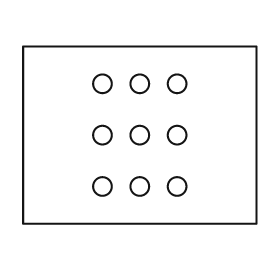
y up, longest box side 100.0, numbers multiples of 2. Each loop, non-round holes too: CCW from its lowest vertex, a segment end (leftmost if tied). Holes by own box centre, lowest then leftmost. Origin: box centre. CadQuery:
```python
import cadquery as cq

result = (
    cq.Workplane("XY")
    .moveTo(-50.0, -38.0)
    .lineTo(50.0, -38.0)
    .lineTo(50.0, 38.0)
    .lineTo(-50.0, 38.0)
    .close()
    .moveTo(-16.0, -22.0)
    .circle(4.0)
    .moveTo(0.0, -22.0)
    .circle(4.0)
    .moveTo(16.0, -22.0)
    .circle(4.0)
    .moveTo(-16.0, 0.0)
    .circle(4.0)
    .moveTo(0.0, 0.0)
    .circle(4.0)
    .moveTo(16.0, 0.0)
    .circle(4.0)
    .moveTo(-16.0, 22.0)
    .circle(4.0)
    .moveTo(0.0, 22.0)
    .circle(4.0)
    .moveTo(16.0, 22.0)
    .circle(4.0)
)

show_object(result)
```